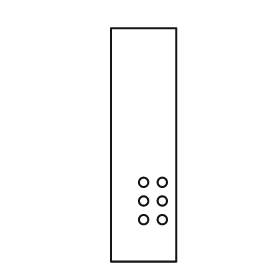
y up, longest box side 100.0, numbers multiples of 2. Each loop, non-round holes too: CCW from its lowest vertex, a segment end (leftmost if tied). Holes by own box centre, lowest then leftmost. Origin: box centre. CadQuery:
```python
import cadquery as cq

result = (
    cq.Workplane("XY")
    .moveTo(-14.0, -50.0)
    .lineTo(14.0, -50.0)
    .lineTo(14.0, 50.0)
    .lineTo(-14.0, 50.0)
    .close()
    .moveTo(0.0, -32.0)
    .circle(2.0)
    .moveTo(8.0, -32.0)
    .circle(2.0)
    .moveTo(0.0, -24.0)
    .circle(2.0)
    .moveTo(8.0, -24.0)
    .circle(2.0)
    .moveTo(0.0, -16.0)
    .circle(2.0)
    .moveTo(8.0, -16.0)
    .circle(2.0)
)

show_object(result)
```